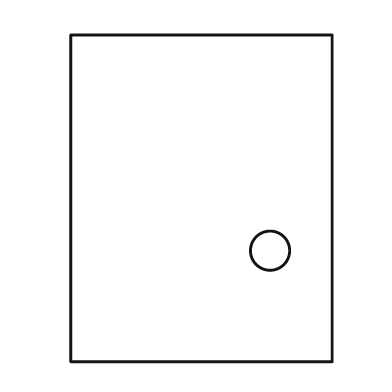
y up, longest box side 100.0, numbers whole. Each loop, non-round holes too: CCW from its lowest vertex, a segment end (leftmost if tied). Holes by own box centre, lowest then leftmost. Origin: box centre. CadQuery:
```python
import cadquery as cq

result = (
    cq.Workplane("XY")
    .moveTo(-40.0, -50.0)
    .lineTo(40.0, -50.0)
    .lineTo(40.0, 50.0)
    .lineTo(-40.0, 50.0)
    .close()
    .moveTo(21.0, -16.0)
    .circle(6.0)
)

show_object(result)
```